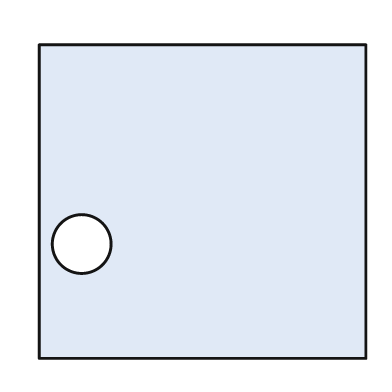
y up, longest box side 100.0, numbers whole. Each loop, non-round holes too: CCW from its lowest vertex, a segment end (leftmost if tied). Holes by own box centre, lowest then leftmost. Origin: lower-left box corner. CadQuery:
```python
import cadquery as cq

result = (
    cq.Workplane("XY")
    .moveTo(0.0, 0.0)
    .lineTo(100.0, 0.0)
    .lineTo(100.0, 96.0)
    .lineTo(0.0, 96.0)
    .close()
    .moveTo(13.0, 35.0)
    .circle(9.0)
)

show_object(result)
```